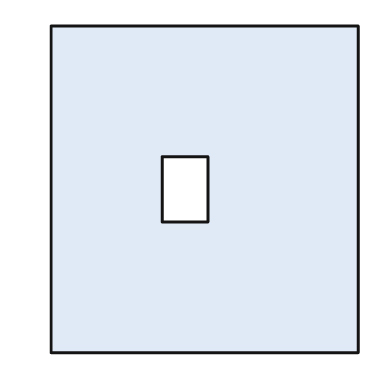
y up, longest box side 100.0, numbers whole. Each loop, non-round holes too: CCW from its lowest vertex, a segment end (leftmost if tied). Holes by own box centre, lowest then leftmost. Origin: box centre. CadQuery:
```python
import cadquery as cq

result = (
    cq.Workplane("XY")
    .moveTo(-47.0, -50.0)
    .lineTo(47.0, -50.0)
    .lineTo(47.0, 50.0)
    .lineTo(-47.0, 50.0)
    .close()
    .moveTo(-13.0, -10.0)
    .lineTo(1.0, -10.0)
    .lineTo(1.0, 10.0)
    .lineTo(-13.0, 10.0)
    .close()
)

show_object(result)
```